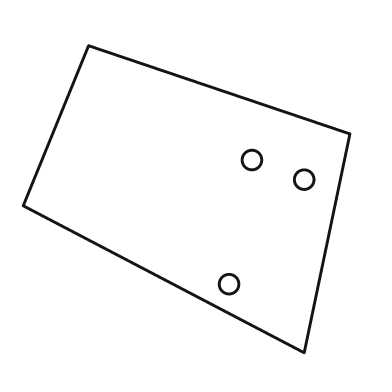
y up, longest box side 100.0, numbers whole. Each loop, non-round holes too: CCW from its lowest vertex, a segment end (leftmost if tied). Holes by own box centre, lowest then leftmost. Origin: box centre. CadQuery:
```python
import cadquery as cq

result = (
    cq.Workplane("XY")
    .moveTo(36.0, -47.0)
    .lineTo(50.0, 20.0)
    .lineTo(-30.0, 47.0)
    .lineTo(-50.0, -2.0)
    .close()
    .moveTo(13.0, -26.0)
    .circle(3.0)
    .moveTo(36.0, 6.0)
    .circle(3.0)
    .moveTo(20.0, 12.0)
    .circle(3.0)
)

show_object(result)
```